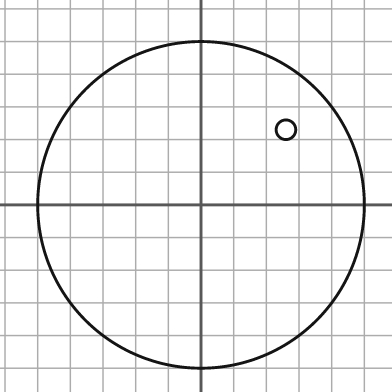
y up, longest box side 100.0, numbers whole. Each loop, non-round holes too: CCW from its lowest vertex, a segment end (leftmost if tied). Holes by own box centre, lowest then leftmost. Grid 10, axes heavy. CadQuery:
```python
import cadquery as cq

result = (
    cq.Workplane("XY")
    .moveTo(0.0, 0.0)
    .circle(50.0)
    .moveTo(26.0, 23.0)
    .circle(3.0)
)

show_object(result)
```